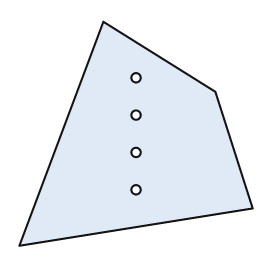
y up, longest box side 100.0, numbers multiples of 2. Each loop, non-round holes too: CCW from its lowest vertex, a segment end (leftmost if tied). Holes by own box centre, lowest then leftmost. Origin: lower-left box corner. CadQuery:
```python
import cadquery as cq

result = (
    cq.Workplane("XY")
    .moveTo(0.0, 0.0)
    .lineTo(100.0, 16.0)
    .lineTo(84.0, 66.0)
    .lineTo(36.0, 96.0)
    .close()
    .moveTo(50.0, 24.0)
    .circle(2.0)
    .moveTo(50.0, 40.0)
    .circle(2.0)
    .moveTo(50.0, 56.0)
    .circle(2.0)
    .moveTo(50.0, 72.0)
    .circle(2.0)
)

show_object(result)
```